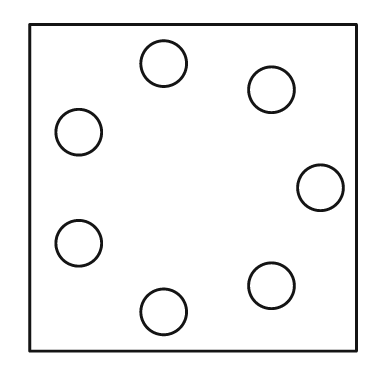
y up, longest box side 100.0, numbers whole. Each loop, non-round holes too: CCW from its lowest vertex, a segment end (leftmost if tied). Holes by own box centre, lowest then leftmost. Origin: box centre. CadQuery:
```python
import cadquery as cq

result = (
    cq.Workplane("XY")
    .moveTo(-50.0, -50.0)
    .lineTo(50.0, -50.0)
    .lineTo(50.0, 50.0)
    .lineTo(-50.0, 50.0)
    .close()
    .moveTo(-9.0, -38.0)
    .circle(7.0)
    .moveTo(24.0, -30.0)
    .circle(7.0)
    .moveTo(-35.0, -17.0)
    .circle(7.0)
    .moveTo(39.0, 0.0)
    .circle(7.0)
    .moveTo(-35.0, 17.0)
    .circle(7.0)
    .moveTo(24.0, 30.0)
    .circle(7.0)
    .moveTo(-9.0, 38.0)
    .circle(7.0)
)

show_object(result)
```